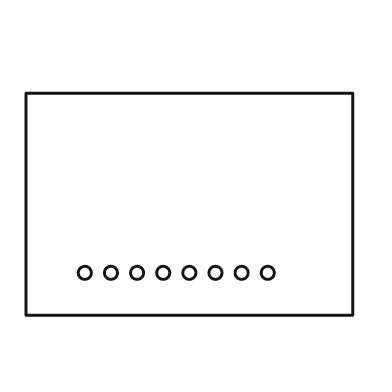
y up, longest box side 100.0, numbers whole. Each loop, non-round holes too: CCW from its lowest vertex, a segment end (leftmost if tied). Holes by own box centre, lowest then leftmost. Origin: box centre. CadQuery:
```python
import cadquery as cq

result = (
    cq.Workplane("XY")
    .moveTo(-50.0, -34.0)
    .lineTo(50.0, -34.0)
    .lineTo(50.0, 34.0)
    .lineTo(-50.0, 34.0)
    .close()
    .moveTo(-32.0, -21.0)
    .circle(2.0)
    .moveTo(-24.0, -21.0)
    .circle(2.0)
    .moveTo(-16.0, -21.0)
    .circle(2.0)
    .moveTo(-8.0, -21.0)
    .circle(2.0)
    .moveTo(0.0, -21.0)
    .circle(2.0)
    .moveTo(8.0, -21.0)
    .circle(2.0)
    .moveTo(16.0, -21.0)
    .circle(2.0)
    .moveTo(24.0, -21.0)
    .circle(2.0)
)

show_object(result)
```